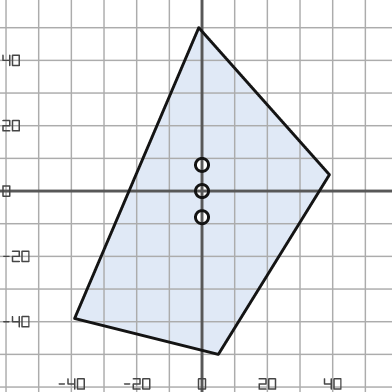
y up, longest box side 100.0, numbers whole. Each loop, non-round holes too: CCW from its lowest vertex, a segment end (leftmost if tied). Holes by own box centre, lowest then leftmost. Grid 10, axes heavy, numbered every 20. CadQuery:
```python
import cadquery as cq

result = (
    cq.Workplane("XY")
    .moveTo(5.0, -50.0)
    .lineTo(39.0, 5.0)
    .lineTo(-1.0, 50.0)
    .lineTo(-39.0, -39.0)
    .close()
    .moveTo(0.0, -8.0)
    .circle(2.0)
    .moveTo(0.0, 0.0)
    .circle(2.0)
    .moveTo(0.0, 8.0)
    .circle(2.0)
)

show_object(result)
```